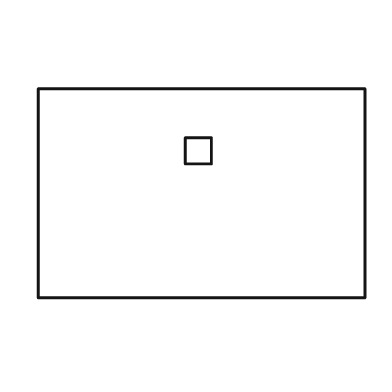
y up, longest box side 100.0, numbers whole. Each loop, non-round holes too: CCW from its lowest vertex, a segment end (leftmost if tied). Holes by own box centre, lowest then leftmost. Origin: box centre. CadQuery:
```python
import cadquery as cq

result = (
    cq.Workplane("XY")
    .moveTo(-50.0, -32.0)
    .lineTo(50.0, -32.0)
    .lineTo(50.0, 32.0)
    .lineTo(-50.0, 32.0)
    .close()
    .moveTo(-5.0, 9.0)
    .lineTo(3.0, 9.0)
    .lineTo(3.0, 17.0)
    .lineTo(-5.0, 17.0)
    .close()
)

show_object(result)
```